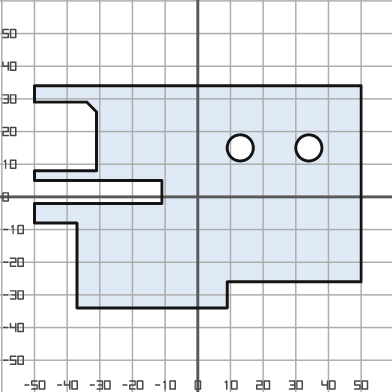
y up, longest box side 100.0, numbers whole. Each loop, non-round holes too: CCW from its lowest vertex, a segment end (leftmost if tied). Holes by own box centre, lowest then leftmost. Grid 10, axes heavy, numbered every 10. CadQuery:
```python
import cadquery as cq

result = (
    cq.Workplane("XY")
    .moveTo(-37.0, -34.0)
    .lineTo(9.0, -34.0)
    .lineTo(9.0, -26.0)
    .lineTo(50.0, -26.0)
    .lineTo(50.0, 34.0)
    .lineTo(-50.0, 34.0)
    .lineTo(-50.0, 29.0)
    .lineTo(-34.0, 29.0)
    .lineTo(-31.0, 26.0)
    .lineTo(-31.0, 8.0)
    .lineTo(-50.0, 8.0)
    .lineTo(-50.0, 5.0)
    .lineTo(-11.0, 5.0)
    .lineTo(-11.0, -2.0)
    .lineTo(-50.0, -2.0)
    .lineTo(-50.0, -8.0)
    .lineTo(-37.0, -8.0)
    .close()
    .moveTo(13.0, 15.0)
    .circle(4.0)
    .moveTo(34.0, 15.0)
    .circle(4.0)
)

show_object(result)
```